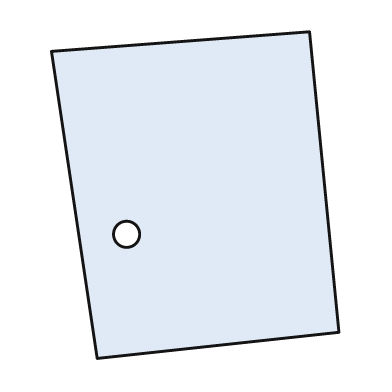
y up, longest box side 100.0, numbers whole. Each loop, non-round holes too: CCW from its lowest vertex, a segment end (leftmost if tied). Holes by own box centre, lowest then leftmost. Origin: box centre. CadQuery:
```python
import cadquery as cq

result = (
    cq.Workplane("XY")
    .moveTo(-30.0, -50.0)
    .lineTo(44.0, -42.0)
    .lineTo(35.0, 50.0)
    .lineTo(-44.0, 44.0)
    .close()
    .moveTo(-21.0, -12.0)
    .circle(4.0)
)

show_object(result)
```